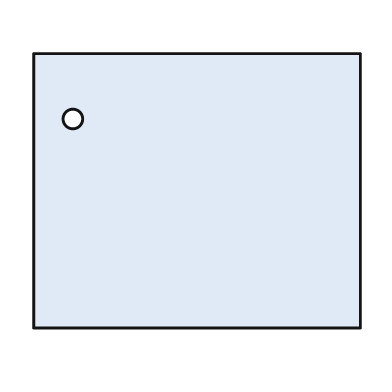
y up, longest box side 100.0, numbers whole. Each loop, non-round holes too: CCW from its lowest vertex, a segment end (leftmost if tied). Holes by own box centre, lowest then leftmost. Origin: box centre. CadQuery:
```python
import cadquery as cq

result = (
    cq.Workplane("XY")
    .moveTo(-50.0, -42.0)
    .lineTo(50.0, -42.0)
    .lineTo(50.0, 42.0)
    .lineTo(-50.0, 42.0)
    .close()
    .moveTo(-38.0, 22.0)
    .circle(3.0)
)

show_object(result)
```